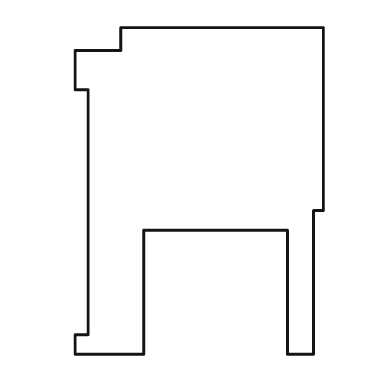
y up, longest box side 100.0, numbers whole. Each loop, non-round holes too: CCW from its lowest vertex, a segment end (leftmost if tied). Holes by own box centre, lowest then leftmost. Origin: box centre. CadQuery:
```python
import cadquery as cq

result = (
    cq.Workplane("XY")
    .moveTo(-38.0, -50.0)
    .lineTo(-17.0, -50.0)
    .lineTo(-17.0, -12.0)
    .lineTo(27.0, -12.0)
    .lineTo(27.0, -50.0)
    .lineTo(35.0, -50.0)
    .lineTo(35.0, -6.0)
    .lineTo(38.0, -6.0)
    .lineTo(38.0, 50.0)
    .lineTo(-24.0, 50.0)
    .lineTo(-24.0, 43.0)
    .lineTo(-38.0, 43.0)
    .lineTo(-38.0, 31.0)
    .lineTo(-34.0, 31.0)
    .lineTo(-34.0, -44.0)
    .lineTo(-38.0, -44.0)
    .close()
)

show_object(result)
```